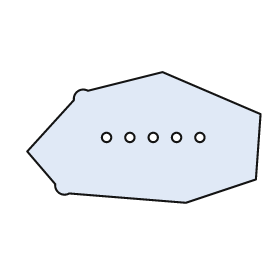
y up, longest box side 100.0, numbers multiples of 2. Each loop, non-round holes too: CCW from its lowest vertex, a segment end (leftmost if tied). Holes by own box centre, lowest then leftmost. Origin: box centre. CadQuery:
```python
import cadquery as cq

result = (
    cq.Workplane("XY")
    .moveTo(18.0, -28.0)
    .lineTo(48.0, -18.0)
    .lineTo(50.0, 10.0)
    .lineTo(8.0, 28.0)
    .lineTo(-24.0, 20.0)
    .threePointArc((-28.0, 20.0), (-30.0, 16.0))
    .lineTo(-50.0, -6.0)
    .lineTo(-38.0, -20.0)
    .threePointArc((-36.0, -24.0), (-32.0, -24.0))
    .close()
    .moveTo(-16.0, 0.0)
    .circle(2.0)
    .moveTo(-6.0, 0.0)
    .circle(2.0)
    .moveTo(4.0, 0.0)
    .circle(2.0)
    .moveTo(14.0, 0.0)
    .circle(2.0)
    .moveTo(24.0, 0.0)
    .circle(2.0)
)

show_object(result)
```